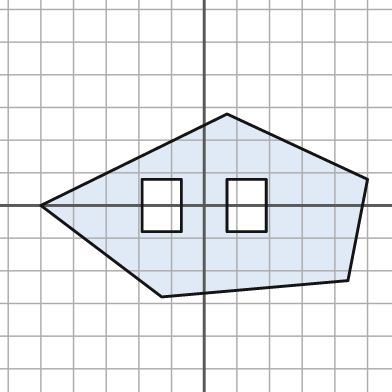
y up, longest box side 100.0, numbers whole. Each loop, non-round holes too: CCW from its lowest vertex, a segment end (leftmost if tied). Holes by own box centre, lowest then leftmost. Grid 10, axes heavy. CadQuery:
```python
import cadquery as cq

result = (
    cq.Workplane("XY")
    .moveTo(-13.0, -28.0)
    .lineTo(44.0, -23.0)
    .lineTo(50.0, 8.0)
    .lineTo(7.0, 28.0)
    .lineTo(-50.0, 0.0)
    .close()
    .moveTo(-19.0, -8.0)
    .lineTo(-7.0, -8.0)
    .lineTo(-7.0, 8.0)
    .lineTo(-19.0, 8.0)
    .close()
    .moveTo(7.0, -8.0)
    .lineTo(19.0, -8.0)
    .lineTo(19.0, 8.0)
    .lineTo(7.0, 8.0)
    .close()
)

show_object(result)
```